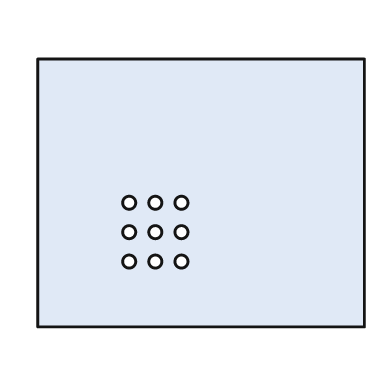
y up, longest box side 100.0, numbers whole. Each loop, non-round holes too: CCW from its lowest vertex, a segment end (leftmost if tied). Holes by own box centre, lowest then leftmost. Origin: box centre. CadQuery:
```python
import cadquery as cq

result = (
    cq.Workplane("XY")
    .moveTo(-50.0, -41.0)
    .lineTo(50.0, -41.0)
    .lineTo(50.0, 41.0)
    .lineTo(-50.0, 41.0)
    .close()
    .moveTo(-22.0, -21.0)
    .circle(2.0)
    .moveTo(-14.0, -21.0)
    .circle(2.0)
    .moveTo(-6.0, -21.0)
    .circle(2.0)
    .moveTo(-22.0, -12.0)
    .circle(2.0)
    .moveTo(-14.0, -12.0)
    .circle(2.0)
    .moveTo(-6.0, -12.0)
    .circle(2.0)
    .moveTo(-22.0, -3.0)
    .circle(2.0)
    .moveTo(-14.0, -3.0)
    .circle(2.0)
    .moveTo(-6.0, -3.0)
    .circle(2.0)
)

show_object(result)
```